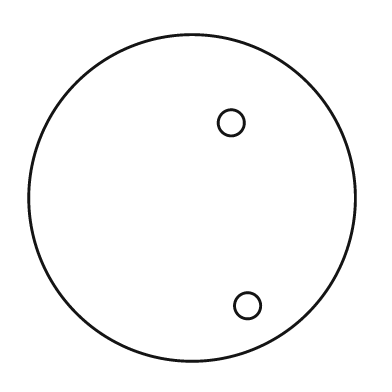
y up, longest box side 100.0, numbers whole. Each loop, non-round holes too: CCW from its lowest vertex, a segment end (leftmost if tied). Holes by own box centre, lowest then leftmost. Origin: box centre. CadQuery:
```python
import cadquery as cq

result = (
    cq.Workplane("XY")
    .moveTo(0.0, 0.0)
    .circle(50.0)
    .moveTo(17.0, -33.0)
    .circle(4.0)
    .moveTo(12.0, 23.0)
    .circle(4.0)
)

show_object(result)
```